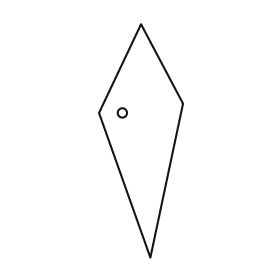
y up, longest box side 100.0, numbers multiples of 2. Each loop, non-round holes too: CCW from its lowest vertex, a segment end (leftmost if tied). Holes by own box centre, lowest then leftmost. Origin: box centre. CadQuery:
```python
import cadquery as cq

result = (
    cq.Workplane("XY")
    .moveTo(4.0, -50.0)
    .lineTo(18.0, 16.0)
    .lineTo(0.0, 50.0)
    .lineTo(-18.0, 12.0)
    .close()
    .moveTo(-8.0, 12.0)
    .circle(2.0)
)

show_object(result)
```